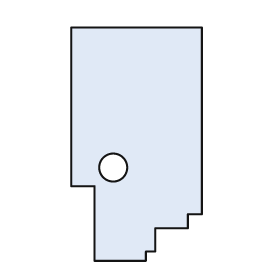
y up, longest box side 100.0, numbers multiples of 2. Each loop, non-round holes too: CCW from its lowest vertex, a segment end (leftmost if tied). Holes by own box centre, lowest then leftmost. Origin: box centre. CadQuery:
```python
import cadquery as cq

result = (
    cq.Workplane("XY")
    .moveTo(-18.0, -50.0)
    .lineTo(4.0, -50.0)
    .lineTo(4.0, -46.0)
    .lineTo(8.0, -46.0)
    .lineTo(8.0, -36.0)
    .lineTo(22.0, -36.0)
    .lineTo(22.0, -30.0)
    .lineTo(28.0, -30.0)
    .lineTo(28.0, 50.0)
    .lineTo(-28.0, 50.0)
    .lineTo(-28.0, -18.0)
    .lineTo(-18.0, -18.0)
    .close()
    .moveTo(-10.0, -10.0)
    .circle(6.0)
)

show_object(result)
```